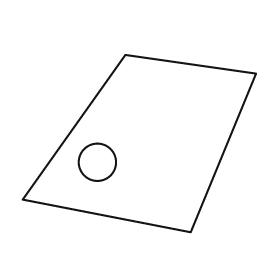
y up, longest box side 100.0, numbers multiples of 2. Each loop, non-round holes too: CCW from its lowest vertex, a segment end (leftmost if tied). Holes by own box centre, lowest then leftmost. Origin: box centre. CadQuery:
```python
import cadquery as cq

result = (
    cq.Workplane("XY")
    .moveTo(22.0, -38.0)
    .lineTo(50.0, 30.0)
    .lineTo(-6.0, 38.0)
    .lineTo(-50.0, -24.0)
    .close()
    .moveTo(-18.0, -8.0)
    .circle(8.0)
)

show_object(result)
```